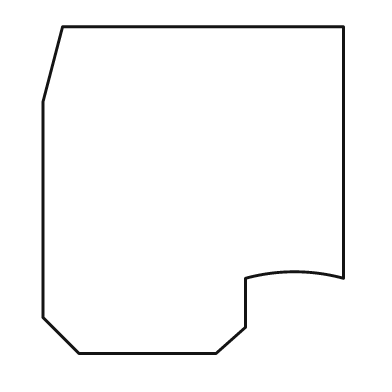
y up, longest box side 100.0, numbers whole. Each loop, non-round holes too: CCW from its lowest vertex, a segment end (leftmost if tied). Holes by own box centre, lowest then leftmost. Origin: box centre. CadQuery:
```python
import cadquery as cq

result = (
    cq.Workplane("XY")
    .moveTo(-35.0, -50.0)
    .lineTo(7.0, -50.0)
    .lineTo(16.0, -42.0)
    .lineTo(16.0, -27.0)
    .threePointArc((31.0, -25.0), (46.0, -27.0))
    .lineTo(46.0, 50.0)
    .lineTo(-40.0, 50.0)
    .lineTo(-46.0, 27.0)
    .lineTo(-46.0, -39.0)
    .close()
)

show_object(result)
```